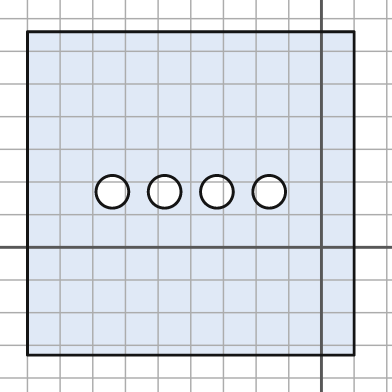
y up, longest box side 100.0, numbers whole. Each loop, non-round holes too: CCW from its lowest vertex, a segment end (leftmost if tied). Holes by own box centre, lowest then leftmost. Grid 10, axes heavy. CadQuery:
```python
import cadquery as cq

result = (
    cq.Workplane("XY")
    .moveTo(-90.0, -33.0)
    .lineTo(10.0, -33.0)
    .lineTo(10.0, 66.0)
    .lineTo(-90.0, 66.0)
    .close()
    .moveTo(-64.0, 17.0)
    .circle(5.0)
    .moveTo(-48.0, 17.0)
    .circle(5.0)
    .moveTo(-32.0, 17.0)
    .circle(5.0)
    .moveTo(-16.0, 17.0)
    .circle(5.0)
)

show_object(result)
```